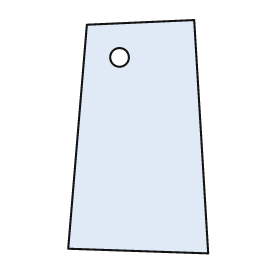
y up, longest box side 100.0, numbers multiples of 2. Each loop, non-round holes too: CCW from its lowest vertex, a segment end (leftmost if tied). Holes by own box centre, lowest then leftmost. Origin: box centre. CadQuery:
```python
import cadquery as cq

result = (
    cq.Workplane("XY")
    .moveTo(30.0, -50.0)
    .lineTo(24.0, 50.0)
    .lineTo(-22.0, 48.0)
    .lineTo(-30.0, -48.0)
    .close()
    .moveTo(-8.0, 34.0)
    .circle(4.0)
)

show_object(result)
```